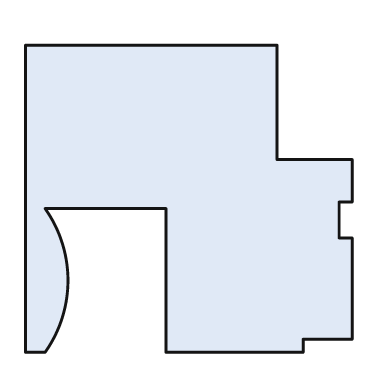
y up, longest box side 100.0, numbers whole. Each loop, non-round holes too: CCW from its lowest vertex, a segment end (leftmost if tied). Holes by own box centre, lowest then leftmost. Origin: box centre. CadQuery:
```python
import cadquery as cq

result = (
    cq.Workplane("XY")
    .moveTo(-50.0, -47.0)
    .lineTo(-44.0, -47.0)
    .threePointArc((-37.0, -25.0), (-44.0, -3.0))
    .lineTo(-7.0, -3.0)
    .lineTo(-7.0, -47.0)
    .lineTo(35.0, -47.0)
    .lineTo(35.0, -43.0)
    .lineTo(50.0, -43.0)
    .lineTo(50.0, -12.0)
    .lineTo(46.0, -12.0)
    .lineTo(46.0, -1.0)
    .lineTo(50.0, -1.0)
    .lineTo(50.0, 12.0)
    .lineTo(27.0, 12.0)
    .lineTo(27.0, 47.0)
    .lineTo(-50.0, 47.0)
    .close()
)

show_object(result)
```